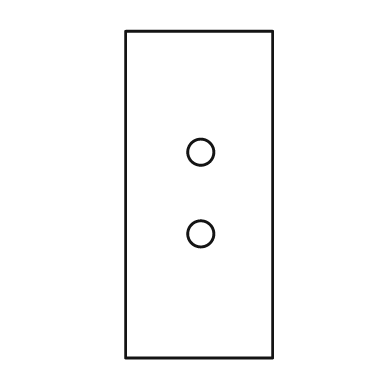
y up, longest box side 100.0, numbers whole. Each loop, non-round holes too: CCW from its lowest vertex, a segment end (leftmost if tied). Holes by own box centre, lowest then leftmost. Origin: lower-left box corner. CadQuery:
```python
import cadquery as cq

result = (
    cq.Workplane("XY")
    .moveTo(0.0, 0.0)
    .lineTo(45.0, 0.0)
    .lineTo(45.0, 100.0)
    .lineTo(0.0, 100.0)
    .close()
    .moveTo(23.0, 38.0)
    .circle(4.0)
    .moveTo(23.0, 63.0)
    .circle(4.0)
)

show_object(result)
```